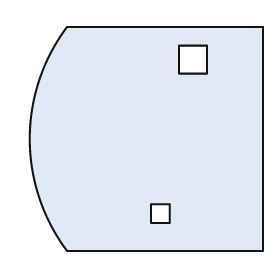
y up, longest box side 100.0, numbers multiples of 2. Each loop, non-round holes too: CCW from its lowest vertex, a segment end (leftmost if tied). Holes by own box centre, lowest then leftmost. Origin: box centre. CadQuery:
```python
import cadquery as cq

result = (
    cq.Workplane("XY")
    .moveTo(-34.0, -48.0)
    .lineTo(50.0, -48.0)
    .lineTo(50.0, 48.0)
    .lineTo(-34.0, 48.0)
    .threePointArc((-50.0, 0.0), (-34.0, -48.0))
    .close()
    .moveTo(2.0, -36.0)
    .lineTo(10.0, -36.0)
    .lineTo(10.0, -28.0)
    .lineTo(2.0, -28.0)
    .close()
    .moveTo(14.0, 28.0)
    .lineTo(26.0, 28.0)
    .lineTo(26.0, 40.0)
    .lineTo(14.0, 40.0)
    .close()
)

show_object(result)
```